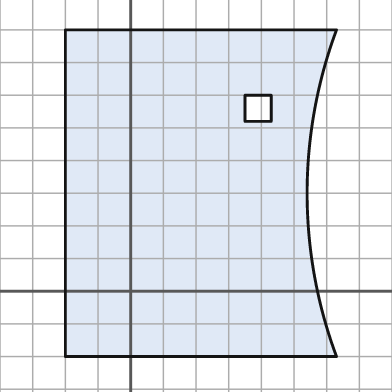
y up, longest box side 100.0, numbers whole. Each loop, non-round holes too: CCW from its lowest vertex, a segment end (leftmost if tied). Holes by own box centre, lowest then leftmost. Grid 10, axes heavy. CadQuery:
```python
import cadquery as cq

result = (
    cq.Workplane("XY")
    .moveTo(-20.0, -20.0)
    .lineTo(63.0, -20.0)
    .threePointArc((54.0, 30.0), (63.0, 80.0))
    .lineTo(-20.0, 80.0)
    .close()
    .moveTo(35.0, 52.0)
    .lineTo(43.0, 52.0)
    .lineTo(43.0, 60.0)
    .lineTo(35.0, 60.0)
    .close()
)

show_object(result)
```